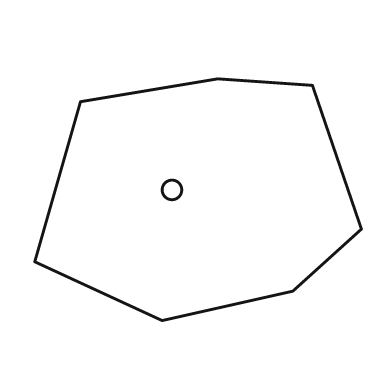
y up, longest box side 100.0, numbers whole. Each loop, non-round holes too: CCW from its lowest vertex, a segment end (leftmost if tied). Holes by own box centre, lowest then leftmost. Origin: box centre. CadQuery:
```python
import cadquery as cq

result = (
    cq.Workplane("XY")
    .moveTo(-11.0, -37.0)
    .lineTo(29.0, -28.0)
    .lineTo(50.0, -9.0)
    .lineTo(35.0, 35.0)
    .lineTo(6.0, 37.0)
    .lineTo(-36.0, 30.0)
    .lineTo(-50.0, -19.0)
    .close()
    .moveTo(-8.0, 3.0)
    .circle(3.0)
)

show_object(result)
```